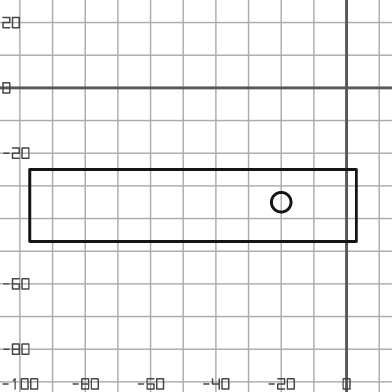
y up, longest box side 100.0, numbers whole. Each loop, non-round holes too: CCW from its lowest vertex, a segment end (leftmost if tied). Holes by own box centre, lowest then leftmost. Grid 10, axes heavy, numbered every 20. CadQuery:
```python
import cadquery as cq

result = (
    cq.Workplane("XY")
    .moveTo(-97.0, -47.0)
    .lineTo(3.0, -47.0)
    .lineTo(3.0, -25.0)
    .lineTo(-97.0, -25.0)
    .close()
    .moveTo(-20.0, -35.0)
    .circle(3.0)
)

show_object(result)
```